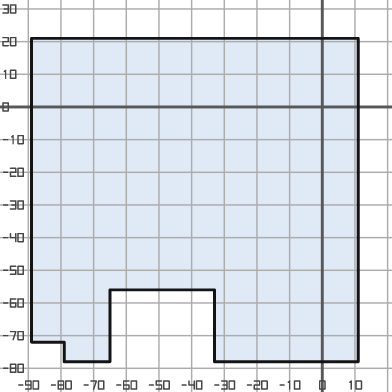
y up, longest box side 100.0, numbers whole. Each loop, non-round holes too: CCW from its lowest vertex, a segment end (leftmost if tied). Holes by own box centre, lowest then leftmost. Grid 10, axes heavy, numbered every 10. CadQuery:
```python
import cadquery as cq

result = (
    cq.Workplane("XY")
    .moveTo(-79.0, -78.0)
    .lineTo(-65.0, -78.0)
    .lineTo(-65.0, -56.0)
    .lineTo(-33.0, -56.0)
    .lineTo(-33.0, -78.0)
    .lineTo(11.0, -78.0)
    .lineTo(11.0, 21.0)
    .lineTo(-89.0, 21.0)
    .lineTo(-89.0, -72.0)
    .lineTo(-79.0, -72.0)
    .close()
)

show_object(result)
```